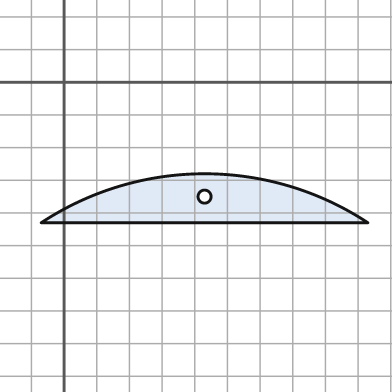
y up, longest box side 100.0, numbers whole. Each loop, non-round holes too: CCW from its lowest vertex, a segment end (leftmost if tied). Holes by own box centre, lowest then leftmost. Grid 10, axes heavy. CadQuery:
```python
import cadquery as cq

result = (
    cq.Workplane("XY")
    .moveTo(-7.0, -43.0)
    .lineTo(93.0, -43.0)
    .threePointArc((43.0, -28.0), (-7.0, -43.0))
    .close()
    .moveTo(43.0, -35.0)
    .circle(2.0)
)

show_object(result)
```